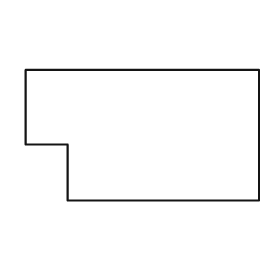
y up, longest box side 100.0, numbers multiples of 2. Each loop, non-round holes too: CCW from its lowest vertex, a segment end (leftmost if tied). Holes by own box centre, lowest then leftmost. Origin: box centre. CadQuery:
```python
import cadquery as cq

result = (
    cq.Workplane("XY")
    .moveTo(-32.0, -28.0)
    .lineTo(50.0, -28.0)
    .lineTo(50.0, 28.0)
    .lineTo(-50.0, 28.0)
    .lineTo(-50.0, -4.0)
    .lineTo(-32.0, -4.0)
    .close()
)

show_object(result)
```